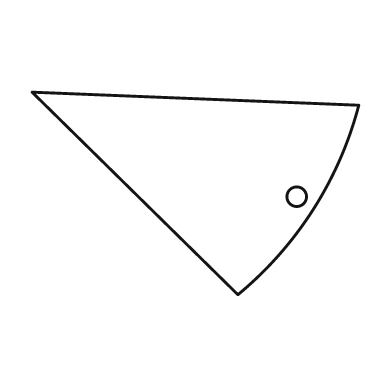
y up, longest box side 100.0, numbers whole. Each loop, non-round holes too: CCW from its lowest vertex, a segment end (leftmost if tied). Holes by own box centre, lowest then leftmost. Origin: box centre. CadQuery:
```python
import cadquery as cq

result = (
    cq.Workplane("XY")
    .moveTo(13.0, -31.0)
    .threePointArc((36.0, -5.0), (50.0, 27.0))
    .lineTo(-50.0, 31.0)
    .close()
    .moveTo(31.0, -1.0)
    .circle(3.0)
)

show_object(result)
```